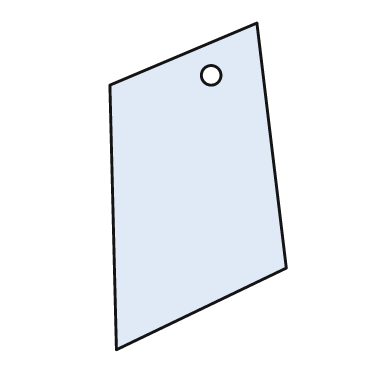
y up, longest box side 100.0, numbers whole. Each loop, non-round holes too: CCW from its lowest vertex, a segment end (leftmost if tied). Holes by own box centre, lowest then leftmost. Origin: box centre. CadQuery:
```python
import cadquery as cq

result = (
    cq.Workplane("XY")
    .moveTo(-25.0, -50.0)
    .lineTo(27.0, -25.0)
    .lineTo(18.0, 50.0)
    .lineTo(-27.0, 31.0)
    .close()
    .moveTo(4.0, 34.0)
    .circle(3.0)
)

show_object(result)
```